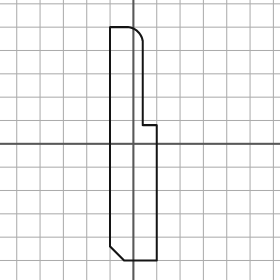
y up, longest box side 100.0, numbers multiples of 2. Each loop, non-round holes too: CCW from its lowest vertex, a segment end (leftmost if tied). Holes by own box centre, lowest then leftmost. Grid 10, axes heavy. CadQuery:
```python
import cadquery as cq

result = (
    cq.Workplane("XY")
    .moveTo(-4.0, -50.0)
    .lineTo(10.0, -50.0)
    .lineTo(10.0, 8.0)
    .lineTo(4.0, 8.0)
    .lineTo(4.0, 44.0)
    .threePointArc((2.0, 48.0), (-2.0, 50.0))
    .lineTo(-10.0, 50.0)
    .lineTo(-10.0, -44.0)
    .close()
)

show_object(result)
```